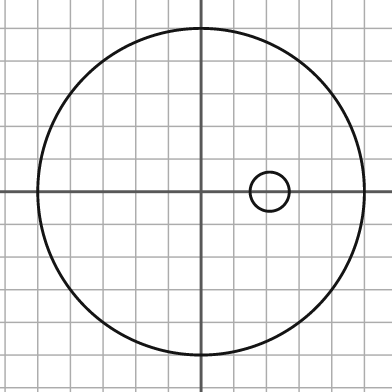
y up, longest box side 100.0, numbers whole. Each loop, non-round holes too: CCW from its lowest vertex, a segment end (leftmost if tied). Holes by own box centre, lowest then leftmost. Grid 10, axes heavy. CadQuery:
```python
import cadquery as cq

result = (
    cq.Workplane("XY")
    .moveTo(0.0, 0.0)
    .circle(50.0)
    .moveTo(21.0, 0.0)
    .circle(6.0)
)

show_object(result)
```